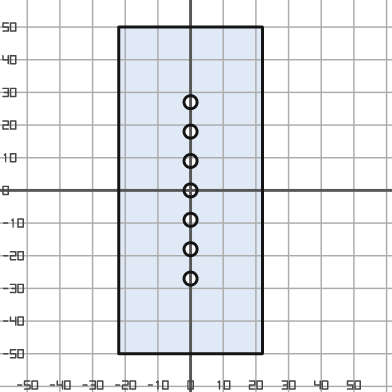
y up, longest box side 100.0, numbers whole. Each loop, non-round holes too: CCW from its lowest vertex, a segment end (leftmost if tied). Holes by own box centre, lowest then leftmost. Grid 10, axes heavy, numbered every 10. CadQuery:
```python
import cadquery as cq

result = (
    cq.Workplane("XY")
    .moveTo(-22.0, -50.0)
    .lineTo(22.0, -50.0)
    .lineTo(22.0, 50.0)
    .lineTo(-22.0, 50.0)
    .close()
    .moveTo(0.0, -27.0)
    .circle(2.0)
    .moveTo(0.0, -18.0)
    .circle(2.0)
    .moveTo(0.0, -9.0)
    .circle(2.0)
    .moveTo(0.0, 0.0)
    .circle(2.0)
    .moveTo(0.0, 9.0)
    .circle(2.0)
    .moveTo(0.0, 18.0)
    .circle(2.0)
    .moveTo(0.0, 27.0)
    .circle(2.0)
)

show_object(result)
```